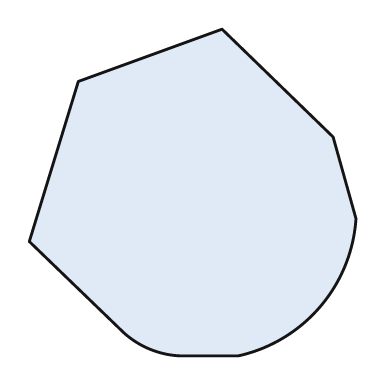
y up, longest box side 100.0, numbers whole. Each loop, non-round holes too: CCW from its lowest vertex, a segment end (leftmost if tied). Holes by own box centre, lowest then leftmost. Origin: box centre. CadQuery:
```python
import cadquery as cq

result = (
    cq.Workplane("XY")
    .moveTo(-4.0, -50.0)
    .lineTo(14.0, -50.0)
    .threePointArc((39.0, -35.0), (50.0, -8.0))
    .lineTo(43.0, 17.0)
    .lineTo(9.0, 50.0)
    .lineTo(-35.0, 34.0)
    .lineTo(-50.0, -15.0)
    .lineTo(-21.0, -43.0)
    .threePointArc((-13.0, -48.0), (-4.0, -50.0))
    .close()
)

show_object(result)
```